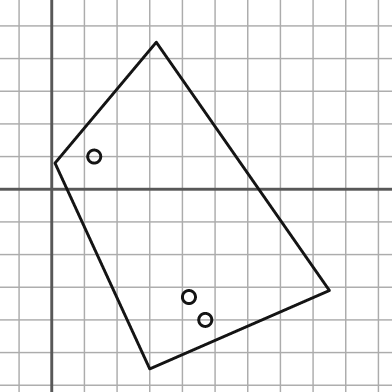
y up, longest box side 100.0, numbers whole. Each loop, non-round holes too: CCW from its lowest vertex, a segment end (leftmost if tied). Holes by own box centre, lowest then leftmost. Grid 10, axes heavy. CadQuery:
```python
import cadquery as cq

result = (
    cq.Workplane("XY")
    .moveTo(30.0, -55.0)
    .lineTo(85.0, -31.0)
    .lineTo(32.0, 45.0)
    .lineTo(1.0, 8.0)
    .close()
    .moveTo(47.0, -40.0)
    .circle(2.0)
    .moveTo(42.0, -33.0)
    .circle(2.0)
    .moveTo(13.0, 10.0)
    .circle(2.0)
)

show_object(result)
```